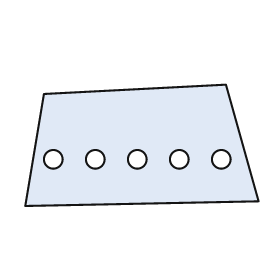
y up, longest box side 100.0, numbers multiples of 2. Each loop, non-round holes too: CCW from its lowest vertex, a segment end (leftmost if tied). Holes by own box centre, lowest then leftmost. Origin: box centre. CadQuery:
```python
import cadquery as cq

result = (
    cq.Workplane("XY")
    .moveTo(-50.0, -26.0)
    .lineTo(50.0, -24.0)
    .lineTo(36.0, 26.0)
    .lineTo(-42.0, 22.0)
    .close()
    .moveTo(-38.0, -6.0)
    .circle(4.0)
    .moveTo(-20.0, -6.0)
    .circle(4.0)
    .moveTo(-2.0, -6.0)
    .circle(4.0)
    .moveTo(16.0, -6.0)
    .circle(4.0)
    .moveTo(34.0, -6.0)
    .circle(4.0)
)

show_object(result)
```